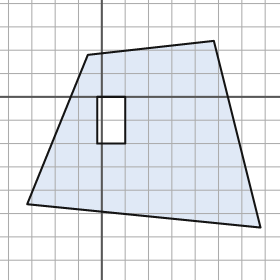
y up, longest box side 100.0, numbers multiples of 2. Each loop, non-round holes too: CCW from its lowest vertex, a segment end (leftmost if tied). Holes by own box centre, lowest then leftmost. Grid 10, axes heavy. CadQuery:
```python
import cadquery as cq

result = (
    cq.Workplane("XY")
    .moveTo(68.0, -56.0)
    .lineTo(48.0, 24.0)
    .lineTo(-6.0, 18.0)
    .lineTo(-32.0, -46.0)
    .close()
    .moveTo(-2.0, -20.0)
    .lineTo(10.0, -20.0)
    .lineTo(10.0, 0.0)
    .lineTo(-2.0, 0.0)
    .close()
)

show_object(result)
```